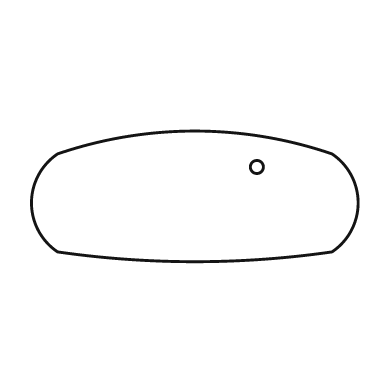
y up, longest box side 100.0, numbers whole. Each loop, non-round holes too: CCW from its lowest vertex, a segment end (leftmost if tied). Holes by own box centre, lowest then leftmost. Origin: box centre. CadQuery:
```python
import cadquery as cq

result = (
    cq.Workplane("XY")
    .moveTo(-42.0, -17.0)
    .threePointArc((0.0, -20.0), (42.0, -17.0))
    .threePointArc((50.0, -2.0), (42.0, 13.0))
    .threePointArc((0.0, 20.0), (-42.0, 13.0))
    .threePointArc((-50.0, -2.0), (-42.0, -17.0))
    .close()
    .moveTo(19.0, 9.0)
    .circle(2.0)
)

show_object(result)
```